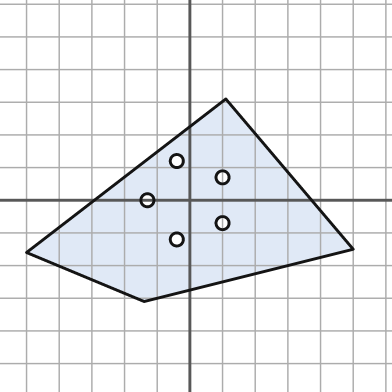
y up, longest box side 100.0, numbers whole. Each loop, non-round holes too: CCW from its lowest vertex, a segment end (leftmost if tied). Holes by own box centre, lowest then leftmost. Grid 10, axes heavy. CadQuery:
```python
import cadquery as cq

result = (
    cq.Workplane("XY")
    .moveTo(-14.0, -31.0)
    .lineTo(50.0, -15.0)
    .lineTo(11.0, 31.0)
    .lineTo(-50.0, -16.0)
    .close()
    .moveTo(-4.0, -12.0)
    .circle(2.0)
    .moveTo(10.0, -7.0)
    .circle(2.0)
    .moveTo(-13.0, 0.0)
    .circle(2.0)
    .moveTo(10.0, 7.0)
    .circle(2.0)
    .moveTo(-4.0, 12.0)
    .circle(2.0)
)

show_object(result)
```